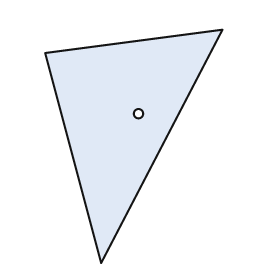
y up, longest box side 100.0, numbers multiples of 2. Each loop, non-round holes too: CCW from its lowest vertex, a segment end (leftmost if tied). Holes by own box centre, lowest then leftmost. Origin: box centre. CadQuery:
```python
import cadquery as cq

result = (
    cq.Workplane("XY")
    .moveTo(-14.0, -50.0)
    .lineTo(38.0, 50.0)
    .lineTo(-38.0, 40.0)
    .close()
    .moveTo(2.0, 14.0)
    .circle(2.0)
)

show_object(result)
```